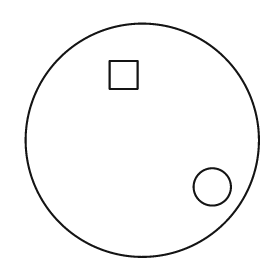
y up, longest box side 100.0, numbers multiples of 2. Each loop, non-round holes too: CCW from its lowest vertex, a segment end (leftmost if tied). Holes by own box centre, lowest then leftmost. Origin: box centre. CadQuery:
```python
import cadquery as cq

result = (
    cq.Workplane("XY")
    .moveTo(0.0, 0.0)
    .circle(50.0)
    .moveTo(30.0, -20.0)
    .circle(8.0)
    .moveTo(-14.0, 22.0)
    .lineTo(-2.0, 22.0)
    .lineTo(-2.0, 34.0)
    .lineTo(-14.0, 34.0)
    .close()
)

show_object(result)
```